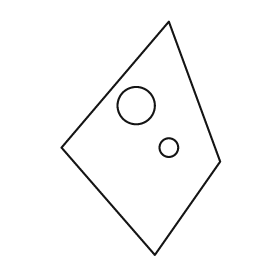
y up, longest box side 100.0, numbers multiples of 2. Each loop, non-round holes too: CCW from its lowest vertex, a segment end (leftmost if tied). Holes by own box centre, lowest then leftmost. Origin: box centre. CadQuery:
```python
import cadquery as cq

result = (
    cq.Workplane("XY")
    .moveTo(6.0, -50.0)
    .lineTo(34.0, -10.0)
    .lineTo(12.0, 50.0)
    .lineTo(-34.0, -4.0)
    .close()
    .moveTo(12.0, -4.0)
    .circle(4.0)
    .moveTo(-2.0, 14.0)
    .circle(8.0)
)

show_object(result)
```